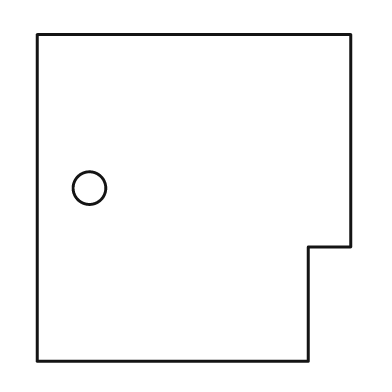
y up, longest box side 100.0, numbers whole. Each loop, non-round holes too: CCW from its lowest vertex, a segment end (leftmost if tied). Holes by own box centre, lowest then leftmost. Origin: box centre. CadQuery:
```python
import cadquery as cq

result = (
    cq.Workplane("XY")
    .moveTo(-48.0, -50.0)
    .lineTo(35.0, -50.0)
    .lineTo(35.0, -15.0)
    .lineTo(48.0, -15.0)
    .lineTo(48.0, 50.0)
    .lineTo(-48.0, 50.0)
    .close()
    .moveTo(-32.0, 3.0)
    .circle(5.0)
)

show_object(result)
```